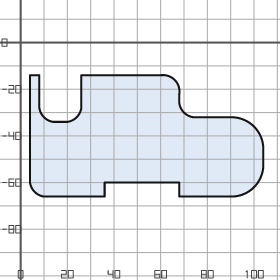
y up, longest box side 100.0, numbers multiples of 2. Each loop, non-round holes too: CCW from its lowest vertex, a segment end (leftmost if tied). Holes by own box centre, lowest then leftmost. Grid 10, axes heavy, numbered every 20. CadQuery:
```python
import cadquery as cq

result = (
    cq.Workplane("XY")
    .moveTo(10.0, -66.0)
    .lineTo(36.0, -66.0)
    .lineTo(36.0, -60.0)
    .lineTo(68.0, -60.0)
    .lineTo(68.0, -66.0)
    .lineTo(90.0, -66.0)
    .threePointArc((100.0, -62.0), (104.0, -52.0))
    .lineTo(104.0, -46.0)
    .threePointArc((100.0, -36.0), (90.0, -32.0))
    .lineTo(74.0, -32.0)
    .threePointArc((70.0, -30.0), (68.0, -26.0))
    .lineTo(68.0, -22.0)
    .threePointArc((66.0, -16.0), (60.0, -14.0))
    .lineTo(26.0, -14.0)
    .lineTo(26.0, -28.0)
    .threePointArc((24.0, -32.0), (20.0, -34.0))
    .lineTo(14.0, -34.0)
    .threePointArc((10.0, -32.0), (8.0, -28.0))
    .lineTo(8.0, -14.0)
    .lineTo(4.0, -14.0)
    .lineTo(4.0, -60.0)
    .threePointArc((6.0, -64.0), (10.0, -66.0))
    .close()
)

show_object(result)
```